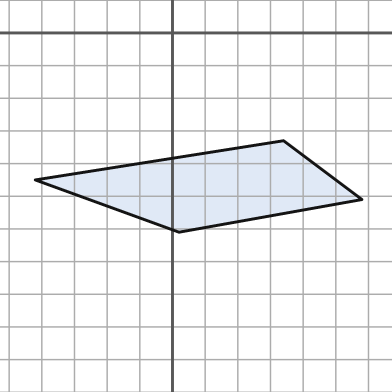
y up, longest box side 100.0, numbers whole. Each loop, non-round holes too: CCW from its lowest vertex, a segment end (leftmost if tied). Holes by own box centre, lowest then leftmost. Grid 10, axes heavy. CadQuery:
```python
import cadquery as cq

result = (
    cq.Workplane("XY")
    .moveTo(2.0, -61.0)
    .lineTo(58.0, -51.0)
    .lineTo(34.0, -33.0)
    .lineTo(-42.0, -45.0)
    .close()
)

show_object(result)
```